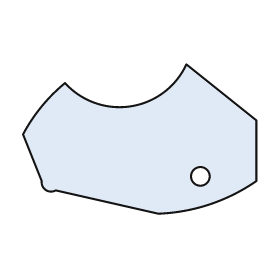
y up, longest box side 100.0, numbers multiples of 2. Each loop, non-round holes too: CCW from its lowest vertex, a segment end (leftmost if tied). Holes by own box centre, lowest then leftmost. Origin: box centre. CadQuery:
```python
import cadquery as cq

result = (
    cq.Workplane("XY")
    .moveTo(8.0, -32.0)
    .threePointArc((30.0, -28.0), (50.0, -18.0))
    .lineTo(50.0, 8.0)
    .lineTo(20.0, 32.0)
    .threePointArc((-4.0, 14.0), (-32.0, 24.0))
    .threePointArc((-42.0, 14.0), (-50.0, 2.0))
    .lineTo(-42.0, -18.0)
    .threePointArc((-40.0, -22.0), (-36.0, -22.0))
    .close()
    .moveTo(26.0, -16.0)
    .circle(4.0)
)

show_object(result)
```